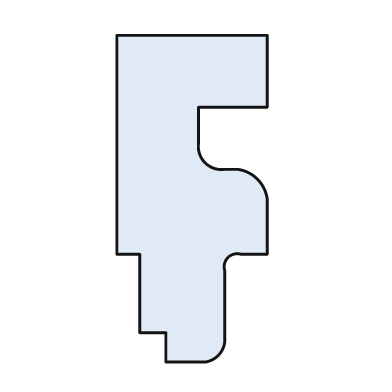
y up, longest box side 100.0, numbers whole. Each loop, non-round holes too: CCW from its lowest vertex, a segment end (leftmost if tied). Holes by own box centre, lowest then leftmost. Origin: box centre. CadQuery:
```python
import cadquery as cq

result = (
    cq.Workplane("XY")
    .moveTo(-8.0, -50.0)
    .lineTo(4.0, -50.0)
    .threePointArc((8.0, -48.0), (10.0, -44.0))
    .lineTo(10.0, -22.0)
    .threePointArc((11.0, -18.0), (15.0, -17.0))
    .lineTo(23.0, -17.0)
    .lineTo(23.0, 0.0)
    .threePointArc((20.0, 6.0), (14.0, 9.0))
    .lineTo(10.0, 9.0)
    .threePointArc((4.0, 11.0), (2.0, 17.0))
    .lineTo(2.0, 28.0)
    .lineTo(23.0, 28.0)
    .lineTo(23.0, 50.0)
    .lineTo(-23.0, 50.0)
    .lineTo(-23.0, -17.0)
    .lineTo(-16.0, -17.0)
    .lineTo(-16.0, -41.0)
    .lineTo(-8.0, -41.0)
    .close()
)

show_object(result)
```